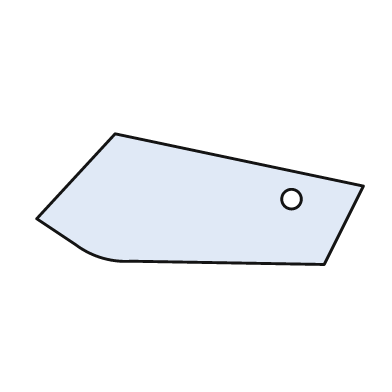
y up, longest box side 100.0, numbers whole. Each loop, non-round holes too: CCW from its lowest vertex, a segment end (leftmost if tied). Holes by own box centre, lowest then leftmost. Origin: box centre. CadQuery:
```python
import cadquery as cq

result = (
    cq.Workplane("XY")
    .moveTo(38.0, -20.0)
    .lineTo(50.0, 4.0)
    .lineTo(-26.0, 20.0)
    .lineTo(-50.0, -6.0)
    .lineTo(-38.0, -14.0)
    .threePointArc((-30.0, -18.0), (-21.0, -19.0))
    .close()
    .moveTo(28.0, 0.0)
    .circle(3.0)
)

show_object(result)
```